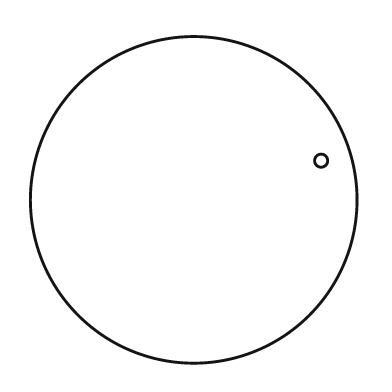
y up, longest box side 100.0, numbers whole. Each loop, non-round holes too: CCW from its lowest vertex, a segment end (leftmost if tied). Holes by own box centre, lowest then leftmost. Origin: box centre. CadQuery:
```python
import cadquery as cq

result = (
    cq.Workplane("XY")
    .moveTo(0.0, 0.0)
    .circle(50.0)
    .moveTo(39.0, 12.0)
    .circle(2.0)
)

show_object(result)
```